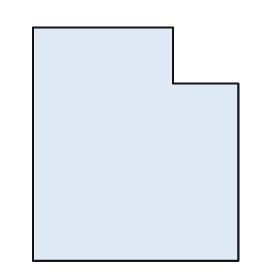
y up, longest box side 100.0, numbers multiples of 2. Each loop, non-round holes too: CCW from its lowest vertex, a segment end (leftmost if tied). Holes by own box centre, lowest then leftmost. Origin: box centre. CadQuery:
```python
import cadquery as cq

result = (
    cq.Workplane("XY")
    .moveTo(-44.0, -50.0)
    .lineTo(44.0, -50.0)
    .lineTo(44.0, 26.0)
    .lineTo(16.0, 26.0)
    .lineTo(16.0, 50.0)
    .lineTo(-44.0, 50.0)
    .close()
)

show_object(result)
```